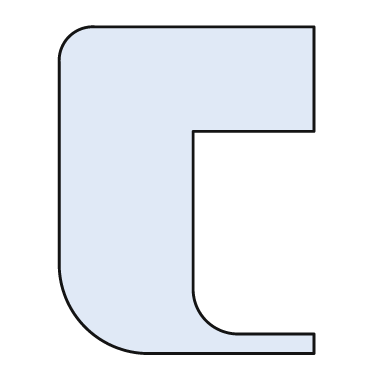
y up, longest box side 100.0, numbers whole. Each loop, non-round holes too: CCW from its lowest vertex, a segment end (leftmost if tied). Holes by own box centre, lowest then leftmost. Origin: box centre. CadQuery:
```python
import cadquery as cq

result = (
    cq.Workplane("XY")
    .moveTo(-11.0, -50.0)
    .lineTo(39.0, -50.0)
    .lineTo(39.0, -44.0)
    .lineTo(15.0, -44.0)
    .threePointArc((6.0, -40.0), (2.0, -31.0))
    .lineTo(2.0, 18.0)
    .lineTo(39.0, 18.0)
    .lineTo(39.0, 50.0)
    .lineTo(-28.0, 50.0)
    .threePointArc((-36.0, 47.0), (-39.0, 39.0))
    .lineTo(-39.0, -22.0)
    .threePointArc((-31.0, -42.0), (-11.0, -50.0))
    .close()
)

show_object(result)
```